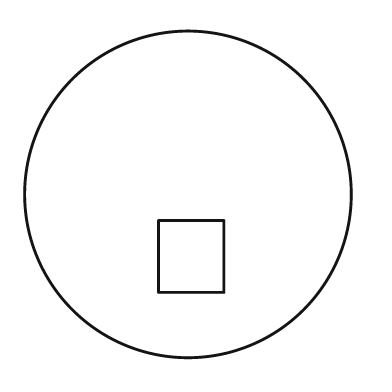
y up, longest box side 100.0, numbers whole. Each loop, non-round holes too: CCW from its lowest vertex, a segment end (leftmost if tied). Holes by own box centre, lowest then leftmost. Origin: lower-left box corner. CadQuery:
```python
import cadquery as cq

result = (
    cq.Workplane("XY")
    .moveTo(50.0, 50.0)
    .circle(50.0)
    .moveTo(41.0, 20.0)
    .lineTo(61.0, 20.0)
    .lineTo(61.0, 42.0)
    .lineTo(41.0, 42.0)
    .close()
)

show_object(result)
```